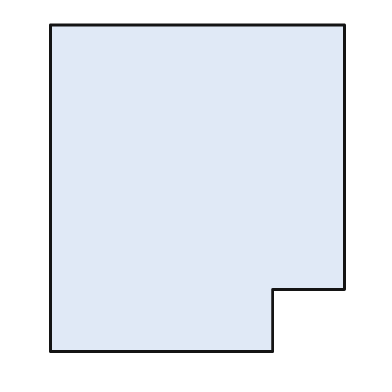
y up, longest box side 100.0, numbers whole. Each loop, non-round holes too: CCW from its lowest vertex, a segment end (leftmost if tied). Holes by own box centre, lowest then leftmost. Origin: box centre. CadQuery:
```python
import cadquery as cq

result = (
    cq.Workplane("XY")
    .moveTo(-45.0, -50.0)
    .lineTo(23.0, -50.0)
    .lineTo(23.0, -31.0)
    .lineTo(45.0, -31.0)
    .lineTo(45.0, 50.0)
    .lineTo(-45.0, 50.0)
    .close()
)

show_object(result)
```